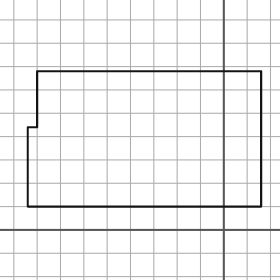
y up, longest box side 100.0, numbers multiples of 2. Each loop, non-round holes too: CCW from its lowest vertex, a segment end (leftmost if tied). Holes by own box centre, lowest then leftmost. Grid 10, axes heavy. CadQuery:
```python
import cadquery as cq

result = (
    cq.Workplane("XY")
    .moveTo(-84.0, 10.0)
    .lineTo(16.0, 10.0)
    .lineTo(16.0, 68.0)
    .lineTo(-80.0, 68.0)
    .lineTo(-80.0, 44.0)
    .lineTo(-84.0, 44.0)
    .close()
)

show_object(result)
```